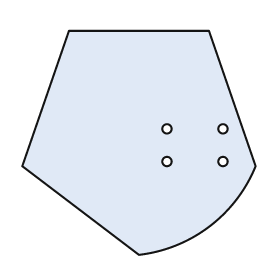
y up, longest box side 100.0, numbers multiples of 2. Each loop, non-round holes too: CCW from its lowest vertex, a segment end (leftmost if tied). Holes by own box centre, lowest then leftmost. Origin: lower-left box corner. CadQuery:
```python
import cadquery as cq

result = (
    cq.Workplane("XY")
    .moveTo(50.0, 0.0)
    .threePointArc((80.0, 12.0), (100.0, 38.0))
    .lineTo(80.0, 96.0)
    .lineTo(20.0, 96.0)
    .lineTo(0.0, 38.0)
    .close()
    .moveTo(62.0, 40.0)
    .circle(2.0)
    .moveTo(86.0, 40.0)
    .circle(2.0)
    .moveTo(62.0, 54.0)
    .circle(2.0)
    .moveTo(86.0, 54.0)
    .circle(2.0)
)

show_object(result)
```